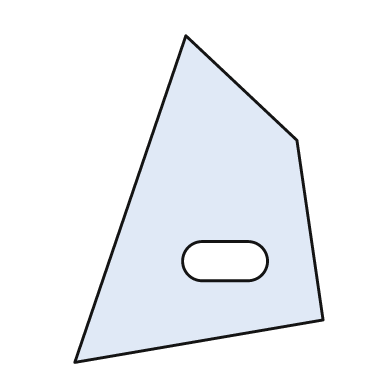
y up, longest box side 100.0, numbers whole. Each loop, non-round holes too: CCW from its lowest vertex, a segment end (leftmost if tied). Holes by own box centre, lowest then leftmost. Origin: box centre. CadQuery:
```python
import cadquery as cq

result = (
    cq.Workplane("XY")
    .moveTo(-38.0, -50.0)
    .lineTo(38.0, -37.0)
    .lineTo(30.0, 18.0)
    .lineTo(-4.0, 50.0)
    .close()
    .moveTo(1.0, -25.0)
    .lineTo(15.0, -25.0)
    .threePointArc((21.0, -19.0), (15.0, -13.0))
    .lineTo(1.0, -13.0)
    .threePointArc((-5.0, -19.0), (1.0, -25.0))
    .close()
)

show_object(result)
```